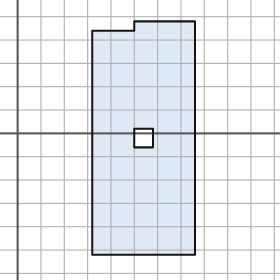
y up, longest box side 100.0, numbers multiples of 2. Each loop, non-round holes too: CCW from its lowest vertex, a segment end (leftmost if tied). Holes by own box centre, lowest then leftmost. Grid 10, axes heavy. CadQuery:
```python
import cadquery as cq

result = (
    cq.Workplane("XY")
    .moveTo(32.0, -52.0)
    .lineTo(76.0, -52.0)
    .lineTo(76.0, 48.0)
    .lineTo(50.0, 48.0)
    .lineTo(50.0, 44.0)
    .lineTo(32.0, 44.0)
    .close()
    .moveTo(50.0, -6.0)
    .lineTo(58.0, -6.0)
    .lineTo(58.0, 2.0)
    .lineTo(50.0, 2.0)
    .close()
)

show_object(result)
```